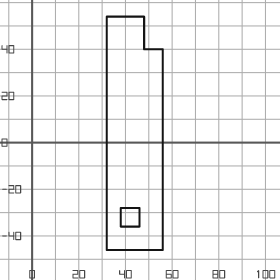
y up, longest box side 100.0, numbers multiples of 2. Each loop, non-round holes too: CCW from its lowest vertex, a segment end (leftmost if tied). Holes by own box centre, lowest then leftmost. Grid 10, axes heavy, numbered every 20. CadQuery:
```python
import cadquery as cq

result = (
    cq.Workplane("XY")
    .moveTo(32.0, -46.0)
    .lineTo(56.0, -46.0)
    .lineTo(56.0, 40.0)
    .lineTo(48.0, 40.0)
    .lineTo(48.0, 54.0)
    .lineTo(32.0, 54.0)
    .close()
    .moveTo(38.0, -36.0)
    .lineTo(46.0, -36.0)
    .lineTo(46.0, -28.0)
    .lineTo(38.0, -28.0)
    .close()
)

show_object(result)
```